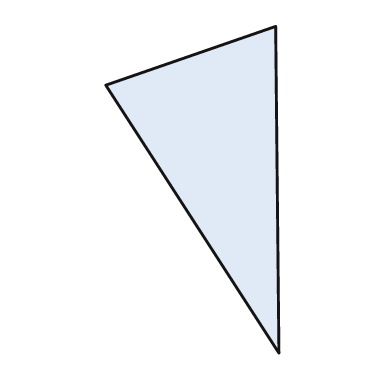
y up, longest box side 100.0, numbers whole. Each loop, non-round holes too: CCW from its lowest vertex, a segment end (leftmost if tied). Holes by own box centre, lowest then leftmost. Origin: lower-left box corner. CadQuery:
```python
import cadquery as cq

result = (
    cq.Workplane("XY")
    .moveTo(53.0, 0.0)
    .lineTo(52.0, 100.0)
    .lineTo(0.0, 82.0)
    .close()
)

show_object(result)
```